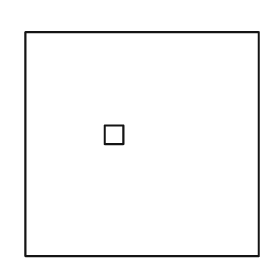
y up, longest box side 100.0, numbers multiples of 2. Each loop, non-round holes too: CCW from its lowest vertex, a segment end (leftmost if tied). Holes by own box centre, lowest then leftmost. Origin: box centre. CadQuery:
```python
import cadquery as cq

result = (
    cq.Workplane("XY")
    .moveTo(-50.0, -48.0)
    .lineTo(50.0, -48.0)
    .lineTo(50.0, 48.0)
    .lineTo(-50.0, 48.0)
    .close()
    .moveTo(-16.0, 0.0)
    .lineTo(-8.0, 0.0)
    .lineTo(-8.0, 8.0)
    .lineTo(-16.0, 8.0)
    .close()
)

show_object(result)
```